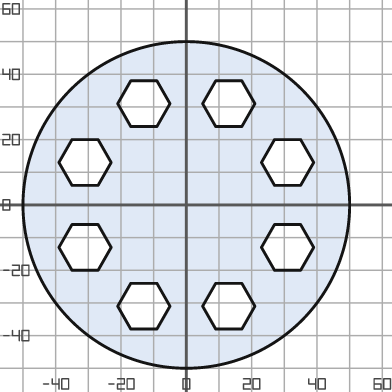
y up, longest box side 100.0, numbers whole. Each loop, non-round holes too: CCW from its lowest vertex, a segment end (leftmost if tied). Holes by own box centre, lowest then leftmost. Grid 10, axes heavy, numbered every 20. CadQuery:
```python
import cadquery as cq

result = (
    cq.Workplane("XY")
    .moveTo(0.0, 0.0)
    .circle(50.0)
    .moveTo(-17.0, -38.0)
    .lineTo(-9.0, -38.0)
    .lineTo(-5.0, -31.0)
    .lineTo(-9.0, -24.0)
    .lineTo(-17.0, -24.0)
    .lineTo(-21.0, -31.0)
    .close()
    .moveTo(9.0, -38.0)
    .lineTo(17.0, -38.0)
    .lineTo(21.0, -31.0)
    .lineTo(17.0, -24.0)
    .lineTo(9.0, -24.0)
    .lineTo(5.0, -31.0)
    .close()
    .moveTo(-35.0, -20.0)
    .lineTo(-27.0, -20.0)
    .lineTo(-23.0, -13.0)
    .lineTo(-27.0, -6.0)
    .lineTo(-35.0, -6.0)
    .lineTo(-39.0, -13.0)
    .close()
    .moveTo(27.0, -20.0)
    .lineTo(35.0, -20.0)
    .lineTo(39.0, -13.0)
    .lineTo(35.0, -6.0)
    .lineTo(27.0, -6.0)
    .lineTo(23.0, -13.0)
    .close()
    .moveTo(-35.0, 6.0)
    .lineTo(-27.0, 6.0)
    .lineTo(-23.0, 13.0)
    .lineTo(-27.0, 20.0)
    .lineTo(-35.0, 20.0)
    .lineTo(-39.0, 13.0)
    .close()
    .moveTo(27.0, 6.0)
    .lineTo(35.0, 6.0)
    .lineTo(39.0, 13.0)
    .lineTo(35.0, 20.0)
    .lineTo(27.0, 20.0)
    .lineTo(23.0, 13.0)
    .close()
    .moveTo(-17.0, 24.0)
    .lineTo(-9.0, 24.0)
    .lineTo(-5.0, 31.0)
    .lineTo(-9.0, 38.0)
    .lineTo(-17.0, 38.0)
    .lineTo(-21.0, 31.0)
    .close()
    .moveTo(9.0, 24.0)
    .lineTo(17.0, 24.0)
    .lineTo(21.0, 31.0)
    .lineTo(17.0, 38.0)
    .lineTo(9.0, 38.0)
    .lineTo(5.0, 31.0)
    .close()
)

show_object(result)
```